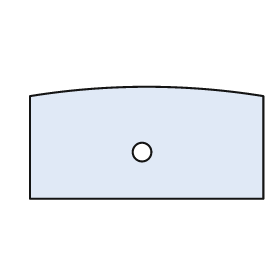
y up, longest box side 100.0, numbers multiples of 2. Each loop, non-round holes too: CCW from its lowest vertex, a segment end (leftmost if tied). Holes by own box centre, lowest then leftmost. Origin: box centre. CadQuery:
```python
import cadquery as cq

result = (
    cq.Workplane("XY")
    .moveTo(-50.0, -24.0)
    .lineTo(50.0, -24.0)
    .lineTo(50.0, 20.0)
    .threePointArc((0.0, 24.0), (-50.0, 20.0))
    .close()
    .moveTo(-2.0, -4.0)
    .circle(4.0)
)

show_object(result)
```